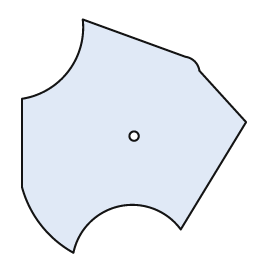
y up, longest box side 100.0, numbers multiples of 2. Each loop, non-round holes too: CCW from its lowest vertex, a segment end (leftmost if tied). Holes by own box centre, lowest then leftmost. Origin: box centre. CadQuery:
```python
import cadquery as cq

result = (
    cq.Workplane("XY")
    .moveTo(-26.0, -50.0)
    .threePointArc((-6.0, -30.0), (20.0, -40.0))
    .lineTo(48.0, 6.0)
    .lineTo(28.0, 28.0)
    .threePointArc((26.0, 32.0), (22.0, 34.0))
    .lineTo(-22.0, 50.0)
    .threePointArc((-28.0, 28.0), (-48.0, 16.0))
    .lineTo(-48.0, -22.0)
    .threePointArc((-40.0, -38.0), (-26.0, -50.0))
    .close()
    .moveTo(0.0, 0.0)
    .circle(2.0)
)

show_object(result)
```